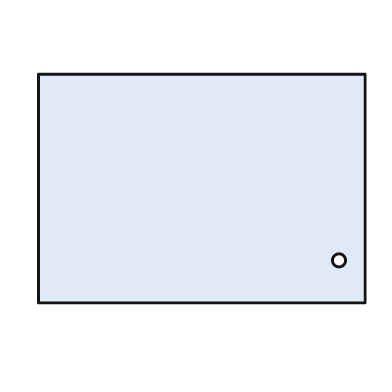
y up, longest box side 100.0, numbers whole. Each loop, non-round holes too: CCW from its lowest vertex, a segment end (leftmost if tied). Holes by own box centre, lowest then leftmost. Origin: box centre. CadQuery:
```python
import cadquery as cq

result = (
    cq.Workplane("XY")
    .moveTo(-50.0, -35.0)
    .lineTo(50.0, -35.0)
    .lineTo(50.0, 35.0)
    .lineTo(-50.0, 35.0)
    .close()
    .moveTo(42.0, -22.0)
    .circle(2.0)
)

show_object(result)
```